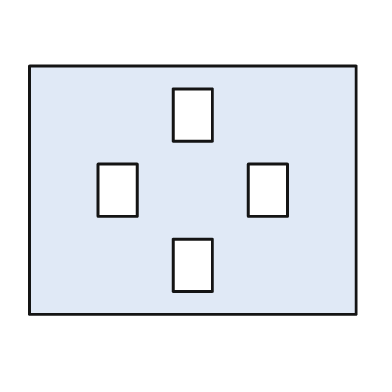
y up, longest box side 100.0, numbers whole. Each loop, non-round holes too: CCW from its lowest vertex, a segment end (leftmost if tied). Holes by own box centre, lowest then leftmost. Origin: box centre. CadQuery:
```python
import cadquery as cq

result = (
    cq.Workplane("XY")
    .moveTo(-50.0, -38.0)
    .lineTo(50.0, -38.0)
    .lineTo(50.0, 38.0)
    .lineTo(-50.0, 38.0)
    .close()
    .moveTo(-6.0, -31.0)
    .lineTo(6.0, -31.0)
    .lineTo(6.0, -15.0)
    .lineTo(-6.0, -15.0)
    .close()
    .moveTo(-29.0, -8.0)
    .lineTo(-17.0, -8.0)
    .lineTo(-17.0, 8.0)
    .lineTo(-29.0, 8.0)
    .close()
    .moveTo(17.0, -8.0)
    .lineTo(29.0, -8.0)
    .lineTo(29.0, 8.0)
    .lineTo(17.0, 8.0)
    .close()
    .moveTo(-6.0, 15.0)
    .lineTo(6.0, 15.0)
    .lineTo(6.0, 31.0)
    .lineTo(-6.0, 31.0)
    .close()
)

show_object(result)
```